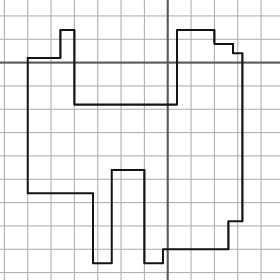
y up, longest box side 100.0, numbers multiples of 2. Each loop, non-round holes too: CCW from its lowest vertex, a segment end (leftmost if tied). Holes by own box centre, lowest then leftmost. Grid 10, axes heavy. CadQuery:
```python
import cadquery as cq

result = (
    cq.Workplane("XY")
    .moveTo(-32.0, -86.0)
    .lineTo(-24.0, -86.0)
    .lineTo(-24.0, -46.0)
    .lineTo(-10.0, -46.0)
    .lineTo(-10.0, -86.0)
    .lineTo(-2.0, -86.0)
    .lineTo(-2.0, -80.0)
    .lineTo(26.0, -80.0)
    .lineTo(26.0, -68.0)
    .lineTo(32.0, -68.0)
    .lineTo(32.0, 4.0)
    .lineTo(28.0, 4.0)
    .lineTo(28.0, 8.0)
    .lineTo(20.0, 8.0)
    .lineTo(20.0, 14.0)
    .lineTo(4.0, 14.0)
    .lineTo(4.0, -18.0)
    .lineTo(-40.0, -18.0)
    .lineTo(-40.0, 14.0)
    .lineTo(-46.0, 14.0)
    .lineTo(-46.0, 2.0)
    .lineTo(-60.0, 2.0)
    .lineTo(-60.0, -56.0)
    .lineTo(-32.0, -56.0)
    .close()
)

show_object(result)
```